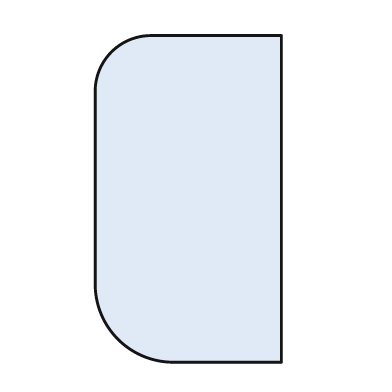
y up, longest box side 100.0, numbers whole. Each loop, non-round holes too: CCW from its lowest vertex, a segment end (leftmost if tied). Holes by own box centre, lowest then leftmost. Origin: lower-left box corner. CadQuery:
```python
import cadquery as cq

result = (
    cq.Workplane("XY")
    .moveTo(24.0, 0.0)
    .lineTo(57.0, 0.0)
    .lineTo(57.0, 100.0)
    .lineTo(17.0, 100.0)
    .threePointArc((5.0, 95.0), (0.0, 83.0))
    .lineTo(0.0, 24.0)
    .threePointArc((7.0, 7.0), (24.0, 0.0))
    .close()
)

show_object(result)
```